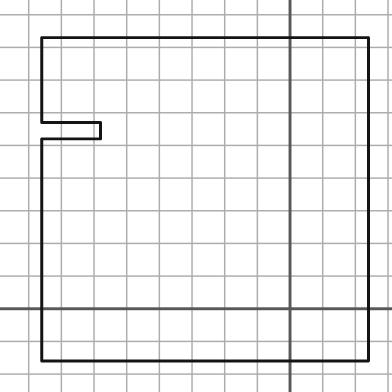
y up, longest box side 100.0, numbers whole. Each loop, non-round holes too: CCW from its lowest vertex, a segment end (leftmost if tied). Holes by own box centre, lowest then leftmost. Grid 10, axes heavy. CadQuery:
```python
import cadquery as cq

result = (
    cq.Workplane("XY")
    .moveTo(-76.0, -16.0)
    .lineTo(24.0, -16.0)
    .lineTo(24.0, 83.0)
    .lineTo(-76.0, 83.0)
    .lineTo(-76.0, 57.0)
    .lineTo(-58.0, 57.0)
    .lineTo(-58.0, 52.0)
    .lineTo(-76.0, 52.0)
    .close()
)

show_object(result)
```